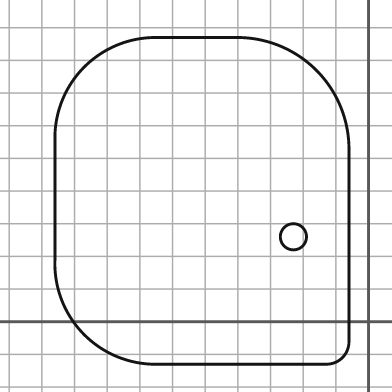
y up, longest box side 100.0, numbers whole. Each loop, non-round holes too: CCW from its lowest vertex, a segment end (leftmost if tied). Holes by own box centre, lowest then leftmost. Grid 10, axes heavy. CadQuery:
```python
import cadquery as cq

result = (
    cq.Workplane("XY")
    .moveTo(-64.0, -13.0)
    .lineTo(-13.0, -13.0)
    .threePointArc((-8.0, -11.0), (-6.0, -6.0))
    .lineTo(-6.0, 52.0)
    .threePointArc((-16.0, 77.0), (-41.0, 87.0))
    .lineTo(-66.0, 87.0)
    .threePointArc((-87.0, 78.0), (-96.0, 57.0))
    .lineTo(-96.0, 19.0)
    .threePointArc((-87.0, -4.0), (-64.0, -13.0))
    .close()
    .moveTo(-23.0, 26.0)
    .circle(4.0)
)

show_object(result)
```